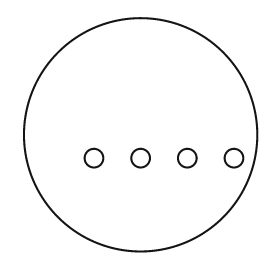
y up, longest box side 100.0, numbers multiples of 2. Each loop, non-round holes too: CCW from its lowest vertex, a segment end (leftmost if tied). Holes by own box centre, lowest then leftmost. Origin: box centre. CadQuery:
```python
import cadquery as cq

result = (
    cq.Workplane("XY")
    .moveTo(0.0, 0.0)
    .circle(50.0)
    .moveTo(-20.0, -10.0)
    .circle(4.0)
    .moveTo(0.0, -10.0)
    .circle(4.0)
    .moveTo(20.0, -10.0)
    .circle(4.0)
    .moveTo(40.0, -10.0)
    .circle(4.0)
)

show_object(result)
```